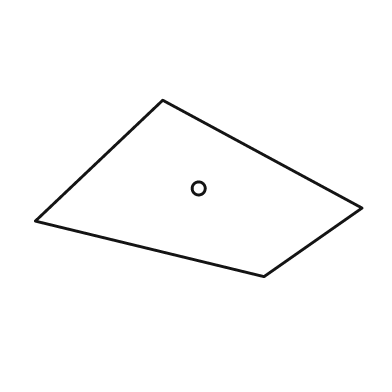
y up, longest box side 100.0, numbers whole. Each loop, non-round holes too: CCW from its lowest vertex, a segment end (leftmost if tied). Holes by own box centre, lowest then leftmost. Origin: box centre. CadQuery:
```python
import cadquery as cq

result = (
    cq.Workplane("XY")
    .moveTo(20.0, -27.0)
    .lineTo(50.0, -6.0)
    .lineTo(-11.0, 27.0)
    .lineTo(-50.0, -10.0)
    .close()
    .moveTo(0.0, 0.0)
    .circle(2.0)
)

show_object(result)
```